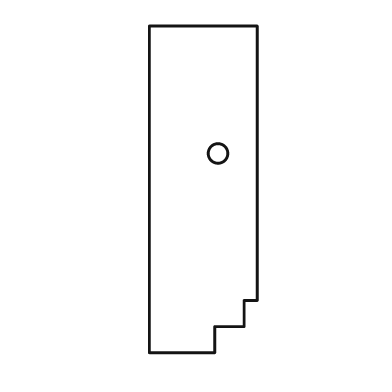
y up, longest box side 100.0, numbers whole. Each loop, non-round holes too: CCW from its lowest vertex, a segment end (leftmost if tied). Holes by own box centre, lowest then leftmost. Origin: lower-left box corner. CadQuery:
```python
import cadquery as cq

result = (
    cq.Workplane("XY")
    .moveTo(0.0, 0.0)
    .lineTo(20.0, 0.0)
    .lineTo(20.0, 8.0)
    .lineTo(29.0, 8.0)
    .lineTo(29.0, 16.0)
    .lineTo(33.0, 16.0)
    .lineTo(33.0, 100.0)
    .lineTo(0.0, 100.0)
    .close()
    .moveTo(21.0, 61.0)
    .circle(3.0)
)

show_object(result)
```